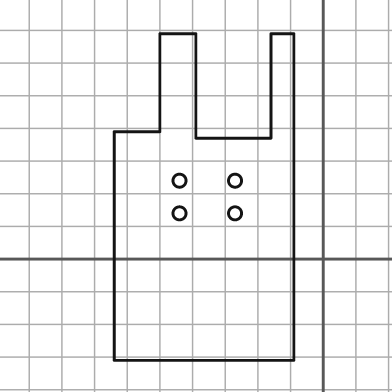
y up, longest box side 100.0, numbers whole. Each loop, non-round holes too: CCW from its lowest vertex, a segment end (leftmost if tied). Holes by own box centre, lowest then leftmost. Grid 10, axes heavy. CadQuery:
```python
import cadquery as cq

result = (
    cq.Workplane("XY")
    .moveTo(-64.0, -31.0)
    .lineTo(-9.0, -31.0)
    .lineTo(-9.0, 69.0)
    .lineTo(-16.0, 69.0)
    .lineTo(-16.0, 37.0)
    .lineTo(-39.0, 37.0)
    .lineTo(-39.0, 69.0)
    .lineTo(-50.0, 69.0)
    .lineTo(-50.0, 39.0)
    .lineTo(-64.0, 39.0)
    .close()
    .moveTo(-44.0, 14.0)
    .circle(2.0)
    .moveTo(-27.0, 14.0)
    .circle(2.0)
    .moveTo(-44.0, 24.0)
    .circle(2.0)
    .moveTo(-27.0, 24.0)
    .circle(2.0)
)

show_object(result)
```